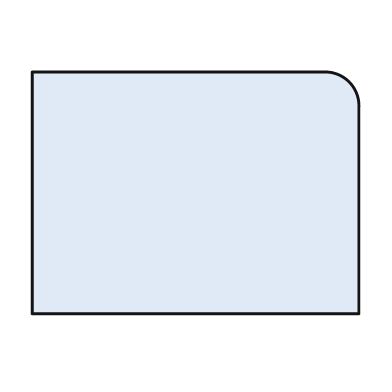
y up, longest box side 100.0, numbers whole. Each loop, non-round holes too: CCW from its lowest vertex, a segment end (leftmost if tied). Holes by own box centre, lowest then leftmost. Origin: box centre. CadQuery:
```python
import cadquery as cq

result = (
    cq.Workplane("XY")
    .moveTo(-50.0, -37.0)
    .lineTo(50.0, -37.0)
    .lineTo(50.0, 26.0)
    .threePointArc((47.0, 34.0), (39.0, 37.0))
    .lineTo(-50.0, 37.0)
    .close()
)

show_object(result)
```